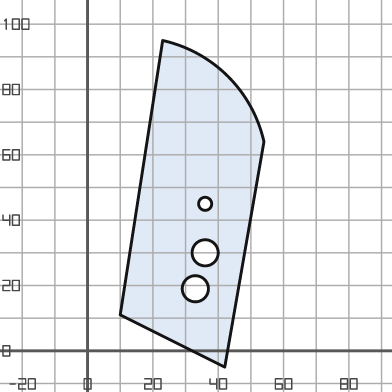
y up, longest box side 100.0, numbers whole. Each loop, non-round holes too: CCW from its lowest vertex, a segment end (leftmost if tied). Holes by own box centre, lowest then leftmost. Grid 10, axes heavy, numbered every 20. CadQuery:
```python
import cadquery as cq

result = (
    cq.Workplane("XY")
    .moveTo(42.0, -5.0)
    .lineTo(54.0, 64.0)
    .threePointArc((43.0, 84.0), (23.0, 95.0))
    .lineTo(10.0, 11.0)
    .close()
    .moveTo(33.0, 19.0)
    .circle(4.0)
    .moveTo(36.0, 30.0)
    .circle(4.0)
    .moveTo(36.0, 45.0)
    .circle(2.0)
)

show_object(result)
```